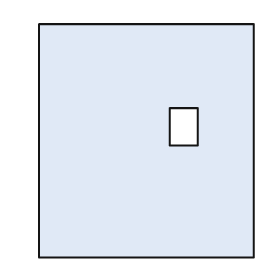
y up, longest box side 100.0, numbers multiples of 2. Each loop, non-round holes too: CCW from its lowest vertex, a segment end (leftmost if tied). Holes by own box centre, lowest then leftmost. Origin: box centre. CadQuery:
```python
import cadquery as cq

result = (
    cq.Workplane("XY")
    .moveTo(-46.0, -50.0)
    .lineTo(46.0, -50.0)
    .lineTo(46.0, 50.0)
    .lineTo(-46.0, 50.0)
    .close()
    .moveTo(10.0, -2.0)
    .lineTo(22.0, -2.0)
    .lineTo(22.0, 14.0)
    .lineTo(10.0, 14.0)
    .close()
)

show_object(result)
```